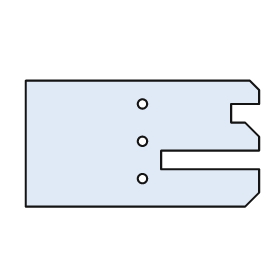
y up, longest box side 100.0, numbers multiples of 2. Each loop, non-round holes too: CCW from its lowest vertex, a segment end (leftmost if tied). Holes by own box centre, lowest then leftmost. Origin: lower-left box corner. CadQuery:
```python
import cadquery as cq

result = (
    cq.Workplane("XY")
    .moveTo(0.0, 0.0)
    .lineTo(94.0, 0.0)
    .lineTo(100.0, 6.0)
    .lineTo(100.0, 16.0)
    .lineTo(58.0, 16.0)
    .lineTo(58.0, 24.0)
    .lineTo(100.0, 24.0)
    .lineTo(100.0, 30.0)
    .lineTo(94.0, 36.0)
    .lineTo(88.0, 36.0)
    .lineTo(88.0, 44.0)
    .lineTo(100.0, 44.0)
    .lineTo(100.0, 50.0)
    .lineTo(96.0, 54.0)
    .lineTo(0.0, 54.0)
    .close()
    .moveTo(50.0, 12.0)
    .circle(2.0)
    .moveTo(50.0, 28.0)
    .circle(2.0)
    .moveTo(50.0, 44.0)
    .circle(2.0)
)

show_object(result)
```